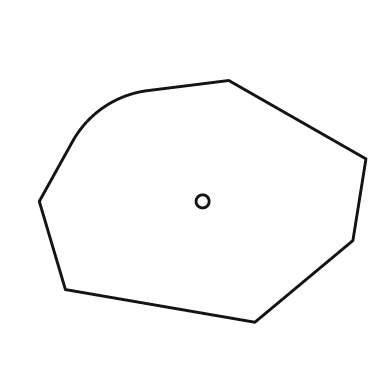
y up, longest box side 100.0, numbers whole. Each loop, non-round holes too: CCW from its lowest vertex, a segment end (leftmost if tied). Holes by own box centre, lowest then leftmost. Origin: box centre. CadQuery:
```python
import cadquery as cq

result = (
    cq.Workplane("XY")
    .moveTo(16.0, -37.0)
    .lineTo(46.0, -12.0)
    .lineTo(50.0, 13.0)
    .lineTo(8.0, 37.0)
    .lineTo(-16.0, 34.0)
    .threePointArc((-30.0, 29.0), (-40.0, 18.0))
    .lineTo(-50.0, 0.0)
    .lineTo(-42.0, -27.0)
    .close()
    .moveTo(0.0, 0.0)
    .circle(2.0)
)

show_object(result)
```